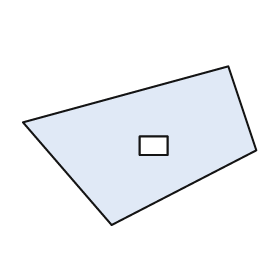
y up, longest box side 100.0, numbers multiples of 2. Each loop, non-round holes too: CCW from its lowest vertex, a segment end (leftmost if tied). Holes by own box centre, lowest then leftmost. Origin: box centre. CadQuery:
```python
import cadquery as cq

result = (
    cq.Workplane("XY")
    .moveTo(-12.0, -34.0)
    .lineTo(50.0, -2.0)
    .lineTo(38.0, 34.0)
    .lineTo(-50.0, 10.0)
    .close()
    .moveTo(0.0, -4.0)
    .lineTo(12.0, -4.0)
    .lineTo(12.0, 4.0)
    .lineTo(0.0, 4.0)
    .close()
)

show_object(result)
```